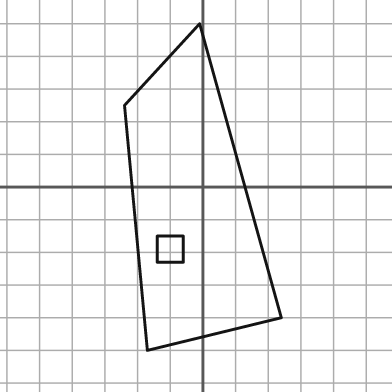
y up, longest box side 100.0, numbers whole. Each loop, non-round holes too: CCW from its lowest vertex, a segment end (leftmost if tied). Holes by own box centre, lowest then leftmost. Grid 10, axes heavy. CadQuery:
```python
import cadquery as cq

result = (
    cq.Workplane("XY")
    .moveTo(-17.0, -50.0)
    .lineTo(24.0, -40.0)
    .lineTo(-1.0, 50.0)
    .lineTo(-24.0, 25.0)
    .close()
    .moveTo(-14.0, -23.0)
    .lineTo(-6.0, -23.0)
    .lineTo(-6.0, -15.0)
    .lineTo(-14.0, -15.0)
    .close()
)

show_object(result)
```